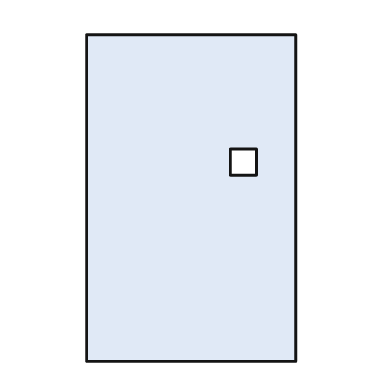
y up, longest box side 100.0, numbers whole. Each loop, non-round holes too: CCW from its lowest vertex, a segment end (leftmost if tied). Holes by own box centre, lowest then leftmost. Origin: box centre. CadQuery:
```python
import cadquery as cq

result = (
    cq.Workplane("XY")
    .moveTo(-32.0, -50.0)
    .lineTo(32.0, -50.0)
    .lineTo(32.0, 50.0)
    .lineTo(-32.0, 50.0)
    .close()
    .moveTo(12.0, 7.0)
    .lineTo(20.0, 7.0)
    .lineTo(20.0, 15.0)
    .lineTo(12.0, 15.0)
    .close()
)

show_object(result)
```